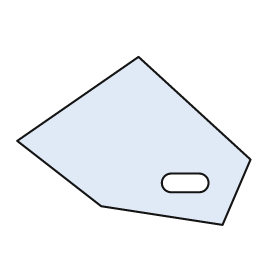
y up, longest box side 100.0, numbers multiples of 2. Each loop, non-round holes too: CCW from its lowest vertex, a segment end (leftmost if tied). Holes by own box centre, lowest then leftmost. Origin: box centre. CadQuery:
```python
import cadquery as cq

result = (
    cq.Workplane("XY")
    .moveTo(38.0, -36.0)
    .lineTo(50.0, -8.0)
    .lineTo(2.0, 36.0)
    .lineTo(-50.0, 0.0)
    .lineTo(-14.0, -28.0)
    .close()
    .moveTo(16.0, -22.0)
    .lineTo(28.0, -22.0)
    .threePointArc((32.0, -18.0), (28.0, -14.0))
    .lineTo(16.0, -14.0)
    .threePointArc((12.0, -18.0), (16.0, -22.0))
    .close()
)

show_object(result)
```